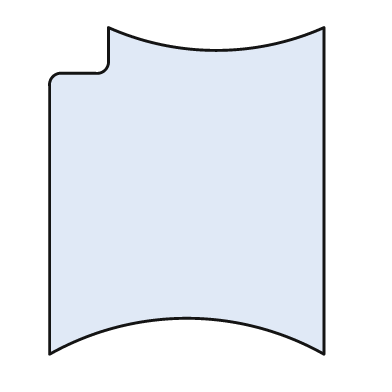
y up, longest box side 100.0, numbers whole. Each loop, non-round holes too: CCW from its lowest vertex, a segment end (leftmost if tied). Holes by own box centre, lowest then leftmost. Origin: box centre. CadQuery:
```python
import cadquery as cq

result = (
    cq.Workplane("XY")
    .moveTo(-42.0, -50.0)
    .threePointArc((0.0, -39.0), (42.0, -50.0))
    .lineTo(42.0, 50.0)
    .threePointArc((9.0, 43.0), (-24.0, 50.0))
    .lineTo(-24.0, 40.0)
    .threePointArc((-25.0, 37.0), (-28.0, 36.0))
    .lineTo(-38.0, 36.0)
    .threePointArc((-41.0, 35.0), (-42.0, 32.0))
    .close()
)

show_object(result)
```